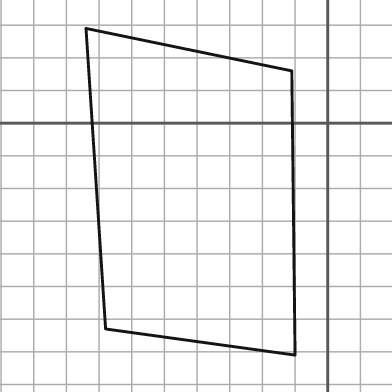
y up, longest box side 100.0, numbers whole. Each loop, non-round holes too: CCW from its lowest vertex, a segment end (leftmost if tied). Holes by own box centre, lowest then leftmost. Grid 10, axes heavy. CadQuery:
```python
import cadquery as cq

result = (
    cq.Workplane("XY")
    .moveTo(-10.0, -71.0)
    .lineTo(-11.0, 16.0)
    .lineTo(-74.0, 29.0)
    .lineTo(-68.0, -63.0)
    .close()
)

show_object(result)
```